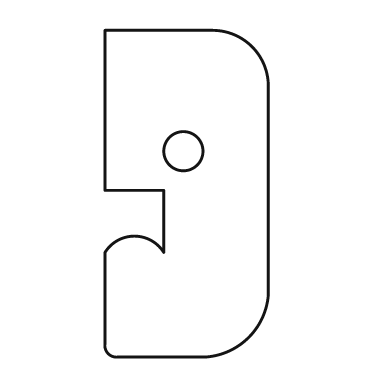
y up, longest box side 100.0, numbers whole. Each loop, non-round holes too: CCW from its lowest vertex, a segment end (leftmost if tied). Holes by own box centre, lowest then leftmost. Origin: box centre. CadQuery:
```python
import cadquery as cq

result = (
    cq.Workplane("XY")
    .moveTo(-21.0, -50.0)
    .lineTo(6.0, -50.0)
    .threePointArc((19.0, -44.0), (25.0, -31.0))
    .lineTo(25.0, 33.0)
    .threePointArc((20.0, 45.0), (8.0, 50.0))
    .lineTo(-25.0, 50.0)
    .lineTo(-25.0, 1.0)
    .lineTo(-7.0, 1.0)
    .lineTo(-7.0, -18.0)
    .threePointArc((-16.0, -13.0), (-25.0, -18.0))
    .lineTo(-25.0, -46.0)
    .threePointArc((-24.0, -49.0), (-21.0, -50.0))
    .close()
    .moveTo(-1.0, 13.0)
    .circle(6.0)
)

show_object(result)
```